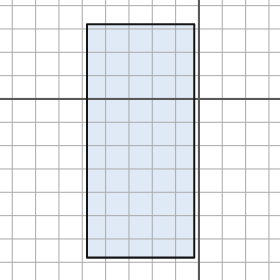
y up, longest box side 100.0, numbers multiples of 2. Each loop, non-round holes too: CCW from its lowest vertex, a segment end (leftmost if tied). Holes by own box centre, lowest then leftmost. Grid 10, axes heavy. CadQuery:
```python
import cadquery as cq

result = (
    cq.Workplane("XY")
    .moveTo(-48.0, -68.0)
    .lineTo(-2.0, -68.0)
    .lineTo(-2.0, 32.0)
    .lineTo(-48.0, 32.0)
    .close()
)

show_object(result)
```